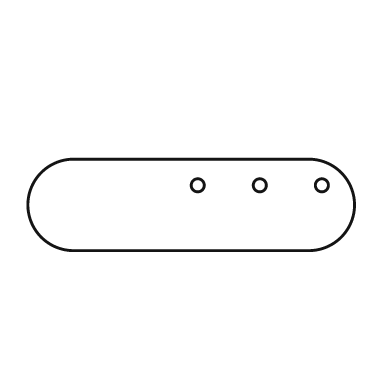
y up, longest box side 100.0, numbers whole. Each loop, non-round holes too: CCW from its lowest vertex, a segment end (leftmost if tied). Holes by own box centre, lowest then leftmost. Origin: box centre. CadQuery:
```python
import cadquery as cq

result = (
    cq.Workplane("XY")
    .moveTo(-36.0, -14.0)
    .lineTo(36.0, -14.0)
    .threePointArc((50.0, 0.0), (36.0, 14.0))
    .lineTo(-36.0, 14.0)
    .threePointArc((-50.0, 0.0), (-36.0, -14.0))
    .close()
    .moveTo(2.0, 6.0)
    .circle(2.0)
    .moveTo(21.0, 6.0)
    .circle(2.0)
    .moveTo(40.0, 6.0)
    .circle(2.0)
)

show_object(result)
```